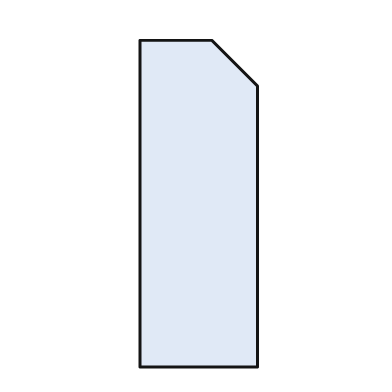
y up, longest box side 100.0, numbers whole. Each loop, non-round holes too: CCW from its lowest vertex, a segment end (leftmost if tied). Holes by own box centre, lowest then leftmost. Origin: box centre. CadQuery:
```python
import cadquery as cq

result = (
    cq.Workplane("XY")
    .moveTo(-18.0, -50.0)
    .lineTo(18.0, -50.0)
    .lineTo(18.0, 36.0)
    .lineTo(4.0, 50.0)
    .lineTo(-18.0, 50.0)
    .close()
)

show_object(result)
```